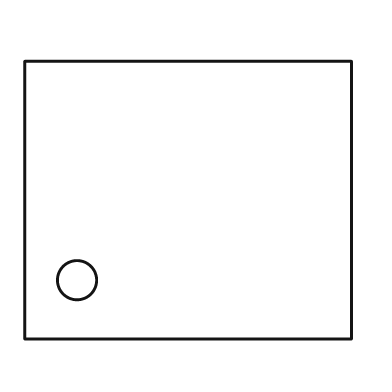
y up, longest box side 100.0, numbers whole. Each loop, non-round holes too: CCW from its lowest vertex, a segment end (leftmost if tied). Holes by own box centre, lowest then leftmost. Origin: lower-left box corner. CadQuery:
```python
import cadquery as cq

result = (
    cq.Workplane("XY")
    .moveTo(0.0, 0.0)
    .lineTo(100.0, 0.0)
    .lineTo(100.0, 85.0)
    .lineTo(0.0, 85.0)
    .close()
    .moveTo(16.0, 18.0)
    .circle(6.0)
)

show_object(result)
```